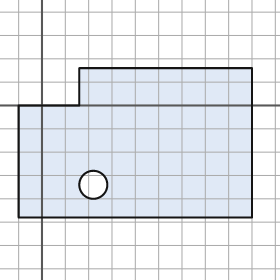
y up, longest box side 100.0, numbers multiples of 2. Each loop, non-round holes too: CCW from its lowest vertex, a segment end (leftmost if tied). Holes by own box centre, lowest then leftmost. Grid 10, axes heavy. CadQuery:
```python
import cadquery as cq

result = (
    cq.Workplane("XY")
    .moveTo(-10.0, -48.0)
    .lineTo(90.0, -48.0)
    .lineTo(90.0, 16.0)
    .lineTo(16.0, 16.0)
    .lineTo(16.0, 0.0)
    .lineTo(-10.0, 0.0)
    .close()
    .moveTo(22.0, -34.0)
    .circle(6.0)
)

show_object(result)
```